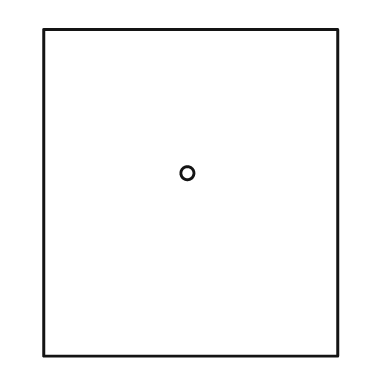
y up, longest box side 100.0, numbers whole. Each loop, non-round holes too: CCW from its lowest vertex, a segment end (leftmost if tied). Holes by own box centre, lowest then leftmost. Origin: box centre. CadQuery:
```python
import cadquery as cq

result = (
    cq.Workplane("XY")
    .moveTo(-45.0, -50.0)
    .lineTo(45.0, -50.0)
    .lineTo(45.0, 50.0)
    .lineTo(-45.0, 50.0)
    .close()
    .moveTo(-1.0, 6.0)
    .circle(2.0)
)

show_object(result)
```